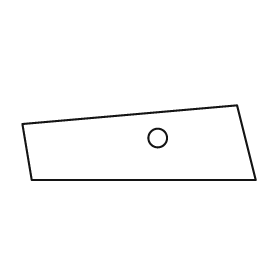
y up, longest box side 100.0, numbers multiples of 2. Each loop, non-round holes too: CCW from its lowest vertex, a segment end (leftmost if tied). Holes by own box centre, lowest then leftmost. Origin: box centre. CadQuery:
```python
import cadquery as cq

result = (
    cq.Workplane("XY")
    .moveTo(-46.0, -16.0)
    .lineTo(50.0, -16.0)
    .lineTo(42.0, 16.0)
    .lineTo(-50.0, 8.0)
    .close()
    .moveTo(8.0, 2.0)
    .circle(4.0)
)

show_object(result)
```